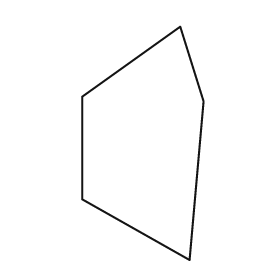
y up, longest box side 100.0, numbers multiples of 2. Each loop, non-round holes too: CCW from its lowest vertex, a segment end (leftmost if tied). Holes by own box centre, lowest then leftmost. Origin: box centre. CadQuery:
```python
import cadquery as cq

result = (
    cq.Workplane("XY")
    .moveTo(20.0, -50.0)
    .lineTo(26.0, 18.0)
    .lineTo(16.0, 50.0)
    .lineTo(-26.0, 20.0)
    .lineTo(-26.0, -24.0)
    .close()
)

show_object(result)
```